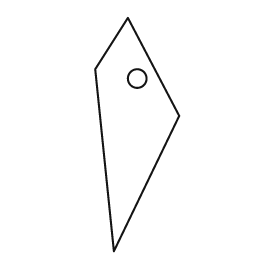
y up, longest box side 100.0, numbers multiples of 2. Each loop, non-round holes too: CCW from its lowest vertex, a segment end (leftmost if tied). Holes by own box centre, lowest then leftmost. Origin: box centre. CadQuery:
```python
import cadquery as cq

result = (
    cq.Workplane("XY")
    .moveTo(-10.0, -50.0)
    .lineTo(18.0, 8.0)
    .lineTo(-4.0, 50.0)
    .lineTo(-18.0, 28.0)
    .close()
    .moveTo(0.0, 24.0)
    .circle(4.0)
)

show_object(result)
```